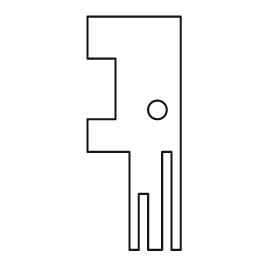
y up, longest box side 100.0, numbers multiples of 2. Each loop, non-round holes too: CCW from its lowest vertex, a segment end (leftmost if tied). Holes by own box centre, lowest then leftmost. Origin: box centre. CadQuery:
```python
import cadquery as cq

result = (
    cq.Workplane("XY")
    .moveTo(-2.0, -50.0)
    .lineTo(2.0, -50.0)
    .lineTo(2.0, -26.0)
    .lineTo(6.0, -26.0)
    .lineTo(6.0, -50.0)
    .lineTo(12.0, -50.0)
    .lineTo(12.0, -8.0)
    .lineTo(16.0, -8.0)
    .lineTo(16.0, -50.0)
    .lineTo(20.0, -50.0)
    .lineTo(20.0, 50.0)
    .lineTo(-20.0, 50.0)
    .lineTo(-20.0, 32.0)
    .lineTo(-8.0, 32.0)
    .lineTo(-8.0, 6.0)
    .lineTo(-20.0, 6.0)
    .lineTo(-20.0, -8.0)
    .lineTo(-2.0, -8.0)
    .close()
    .moveTo(10.0, 10.0)
    .circle(4.0)
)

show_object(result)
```